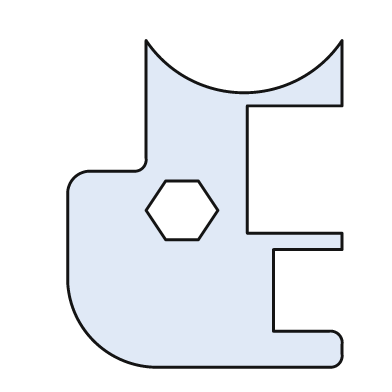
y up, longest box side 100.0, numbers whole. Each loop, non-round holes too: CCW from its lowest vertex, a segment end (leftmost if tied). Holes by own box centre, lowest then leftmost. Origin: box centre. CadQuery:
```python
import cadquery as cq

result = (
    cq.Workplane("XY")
    .moveTo(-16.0, -50.0)
    .lineTo(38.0, -50.0)
    .threePointArc((41.0, -49.0), (42.0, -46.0))
    .lineTo(42.0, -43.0)
    .threePointArc((41.0, -40.0), (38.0, -39.0))
    .lineTo(21.0, -39.0)
    .lineTo(21.0, -14.0)
    .lineTo(42.0, -14.0)
    .lineTo(42.0, -9.0)
    .lineTo(13.0, -9.0)
    .lineTo(13.0, 30.0)
    .lineTo(42.0, 30.0)
    .lineTo(42.0, 50.0)
    .threePointArc((12.0, 34.0), (-18.0, 50.0))
    .lineTo(-18.0, 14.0)
    .threePointArc((-19.0, 11.0), (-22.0, 10.0))
    .lineTo(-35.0, 10.0)
    .threePointArc((-40.0, 8.0), (-42.0, 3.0))
    .lineTo(-42.0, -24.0)
    .threePointArc((-34.0, -42.0), (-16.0, -50.0))
    .close()
    .moveTo(-12.0, -11.0)
    .lineTo(-2.0, -11.0)
    .lineTo(4.0, -2.0)
    .lineTo(-2.0, 7.0)
    .lineTo(-12.0, 7.0)
    .lineTo(-18.0, -2.0)
    .close()
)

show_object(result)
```